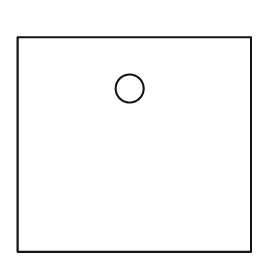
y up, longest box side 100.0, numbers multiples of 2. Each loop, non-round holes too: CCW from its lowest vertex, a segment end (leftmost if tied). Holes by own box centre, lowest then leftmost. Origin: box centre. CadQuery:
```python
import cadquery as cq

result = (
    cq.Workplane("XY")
    .moveTo(-50.0, -46.0)
    .lineTo(50.0, -46.0)
    .lineTo(50.0, 46.0)
    .lineTo(-50.0, 46.0)
    .close()
    .moveTo(-2.0, 24.0)
    .circle(6.0)
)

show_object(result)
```